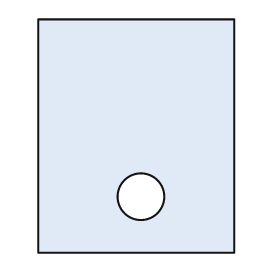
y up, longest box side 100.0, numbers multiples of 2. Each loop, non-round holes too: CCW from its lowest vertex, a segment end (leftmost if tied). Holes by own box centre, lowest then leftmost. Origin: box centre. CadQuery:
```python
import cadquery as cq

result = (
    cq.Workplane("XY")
    .moveTo(-42.0, -50.0)
    .lineTo(42.0, -50.0)
    .lineTo(42.0, 50.0)
    .lineTo(-42.0, 50.0)
    .close()
    .moveTo(2.0, -26.0)
    .circle(10.0)
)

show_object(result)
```